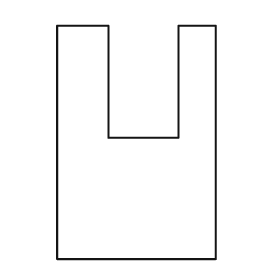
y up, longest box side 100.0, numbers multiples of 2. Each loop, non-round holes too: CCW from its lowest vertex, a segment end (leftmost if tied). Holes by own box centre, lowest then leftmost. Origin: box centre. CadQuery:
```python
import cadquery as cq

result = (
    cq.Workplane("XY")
    .moveTo(-34.0, -50.0)
    .lineTo(34.0, -50.0)
    .lineTo(34.0, 50.0)
    .lineTo(18.0, 50.0)
    .lineTo(18.0, 2.0)
    .lineTo(-12.0, 2.0)
    .lineTo(-12.0, 50.0)
    .lineTo(-34.0, 50.0)
    .close()
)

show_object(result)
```